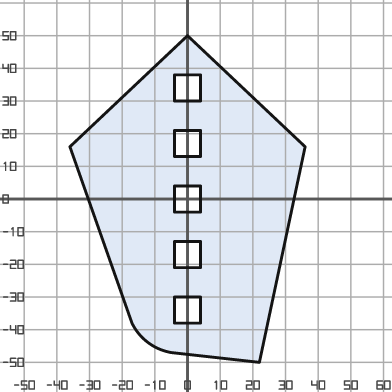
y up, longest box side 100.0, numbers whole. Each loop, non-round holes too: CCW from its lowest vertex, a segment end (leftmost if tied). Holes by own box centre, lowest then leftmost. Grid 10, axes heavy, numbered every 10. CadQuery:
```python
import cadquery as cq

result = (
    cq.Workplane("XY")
    .moveTo(22.0, -50.0)
    .lineTo(36.0, 16.0)
    .lineTo(0.0, 50.0)
    .lineTo(-36.0, 16.0)
    .lineTo(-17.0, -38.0)
    .threePointArc((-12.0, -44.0), (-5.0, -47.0))
    .close()
    .moveTo(-4.0, -38.0)
    .lineTo(4.0, -38.0)
    .lineTo(4.0, -30.0)
    .lineTo(-4.0, -30.0)
    .close()
    .moveTo(-4.0, -21.0)
    .lineTo(4.0, -21.0)
    .lineTo(4.0, -13.0)
    .lineTo(-4.0, -13.0)
    .close()
    .moveTo(-4.0, -4.0)
    .lineTo(4.0, -4.0)
    .lineTo(4.0, 4.0)
    .lineTo(-4.0, 4.0)
    .close()
    .moveTo(-4.0, 13.0)
    .lineTo(4.0, 13.0)
    .lineTo(4.0, 21.0)
    .lineTo(-4.0, 21.0)
    .close()
    .moveTo(-4.0, 30.0)
    .lineTo(4.0, 30.0)
    .lineTo(4.0, 38.0)
    .lineTo(-4.0, 38.0)
    .close()
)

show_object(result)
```